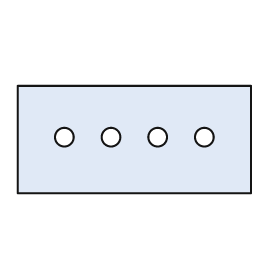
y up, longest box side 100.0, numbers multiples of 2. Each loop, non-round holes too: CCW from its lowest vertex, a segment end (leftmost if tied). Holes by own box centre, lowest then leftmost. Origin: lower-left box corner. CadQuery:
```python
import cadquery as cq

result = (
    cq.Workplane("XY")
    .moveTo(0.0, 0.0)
    .lineTo(100.0, 0.0)
    .lineTo(100.0, 46.0)
    .lineTo(0.0, 46.0)
    .close()
    .moveTo(20.0, 24.0)
    .circle(4.0)
    .moveTo(40.0, 24.0)
    .circle(4.0)
    .moveTo(60.0, 24.0)
    .circle(4.0)
    .moveTo(80.0, 24.0)
    .circle(4.0)
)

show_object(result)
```